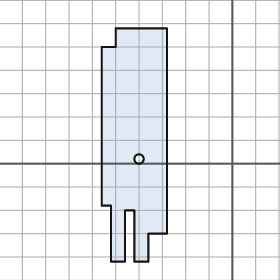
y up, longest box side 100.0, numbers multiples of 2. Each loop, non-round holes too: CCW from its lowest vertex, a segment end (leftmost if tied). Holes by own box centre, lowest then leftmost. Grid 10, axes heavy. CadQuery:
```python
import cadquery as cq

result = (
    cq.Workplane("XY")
    .moveTo(-52.0, -42.0)
    .lineTo(-46.0, -42.0)
    .lineTo(-46.0, -20.0)
    .lineTo(-42.0, -20.0)
    .lineTo(-42.0, -42.0)
    .lineTo(-36.0, -42.0)
    .lineTo(-36.0, -30.0)
    .lineTo(-28.0, -30.0)
    .lineTo(-28.0, 58.0)
    .lineTo(-50.0, 58.0)
    .lineTo(-50.0, 50.0)
    .lineTo(-56.0, 50.0)
    .lineTo(-56.0, -18.0)
    .lineTo(-52.0, -18.0)
    .close()
    .moveTo(-40.0, 2.0)
    .circle(2.0)
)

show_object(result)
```